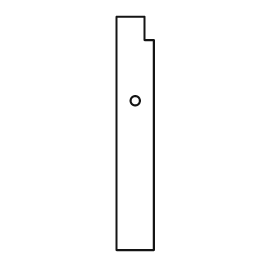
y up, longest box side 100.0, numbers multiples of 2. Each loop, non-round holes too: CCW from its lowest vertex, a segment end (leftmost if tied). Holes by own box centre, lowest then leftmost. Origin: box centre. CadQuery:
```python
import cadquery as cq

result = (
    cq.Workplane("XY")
    .moveTo(-8.0, -50.0)
    .lineTo(8.0, -50.0)
    .lineTo(8.0, 40.0)
    .lineTo(4.0, 40.0)
    .lineTo(4.0, 50.0)
    .lineTo(-8.0, 50.0)
    .close()
    .moveTo(0.0, 14.0)
    .circle(2.0)
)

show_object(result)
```